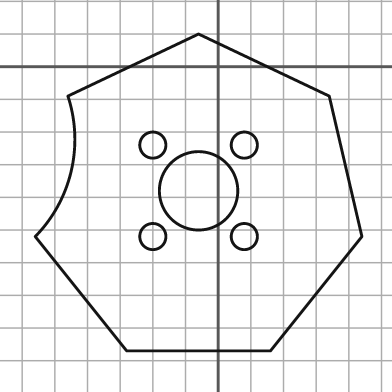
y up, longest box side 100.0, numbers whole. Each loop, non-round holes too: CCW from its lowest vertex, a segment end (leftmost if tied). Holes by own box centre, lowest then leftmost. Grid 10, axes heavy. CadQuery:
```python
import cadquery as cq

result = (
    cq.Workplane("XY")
    .moveTo(-28.0, -87.0)
    .lineTo(16.0, -87.0)
    .lineTo(44.0, -52.0)
    .lineTo(34.0, -9.0)
    .lineTo(-6.0, 10.0)
    .lineTo(-46.0, -9.0)
    .threePointArc((-45.0, -32.0), (-56.0, -52.0))
    .close()
    .moveTo(-20.0, -52.0)
    .circle(4.0)
    .moveTo(8.0, -52.0)
    .circle(4.0)
    .moveTo(-6.0, -38.0)
    .circle(12.0)
    .moveTo(-20.0, -24.0)
    .circle(4.0)
    .moveTo(8.0, -24.0)
    .circle(4.0)
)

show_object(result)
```